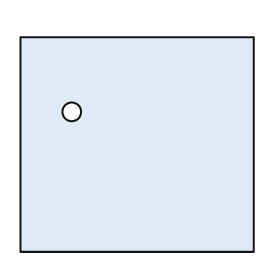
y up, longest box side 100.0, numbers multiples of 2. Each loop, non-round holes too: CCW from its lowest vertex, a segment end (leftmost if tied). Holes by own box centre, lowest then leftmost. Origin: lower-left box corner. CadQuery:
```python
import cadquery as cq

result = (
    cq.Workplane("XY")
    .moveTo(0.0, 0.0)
    .lineTo(100.0, 0.0)
    .lineTo(100.0, 92.0)
    .lineTo(0.0, 92.0)
    .close()
    .moveTo(22.0, 60.0)
    .circle(4.0)
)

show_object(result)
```